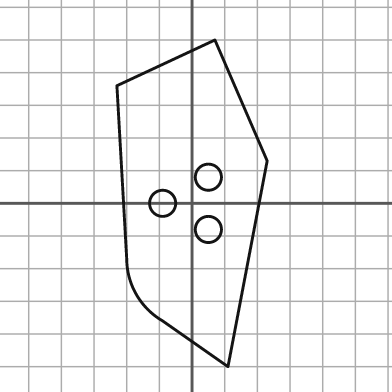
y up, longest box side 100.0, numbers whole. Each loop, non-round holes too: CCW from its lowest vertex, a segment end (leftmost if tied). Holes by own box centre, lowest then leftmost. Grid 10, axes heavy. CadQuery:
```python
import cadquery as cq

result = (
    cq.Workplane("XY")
    .moveTo(11.0, -50.0)
    .lineTo(23.0, 13.0)
    .lineTo(7.0, 50.0)
    .lineTo(-23.0, 36.0)
    .lineTo(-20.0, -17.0)
    .threePointArc((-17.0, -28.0), (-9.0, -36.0))
    .close()
    .moveTo(5.0, -8.0)
    .circle(4.0)
    .moveTo(-9.0, 0.0)
    .circle(4.0)
    .moveTo(5.0, 8.0)
    .circle(4.0)
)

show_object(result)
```